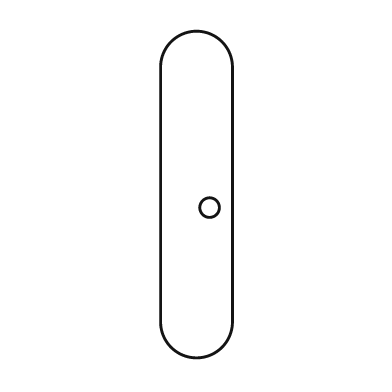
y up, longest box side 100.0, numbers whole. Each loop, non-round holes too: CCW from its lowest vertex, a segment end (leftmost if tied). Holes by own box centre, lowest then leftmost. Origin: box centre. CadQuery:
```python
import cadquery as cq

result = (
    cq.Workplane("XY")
    .moveTo(-11.0, -39.0)
    .threePointArc((0.0, -50.0), (11.0, -39.0))
    .lineTo(11.0, 39.0)
    .threePointArc((0.0, 50.0), (-11.0, 39.0))
    .close()
    .moveTo(4.0, -4.0)
    .circle(3.0)
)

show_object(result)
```